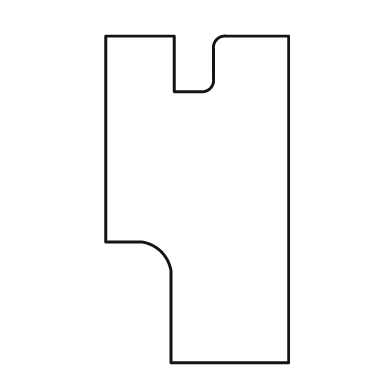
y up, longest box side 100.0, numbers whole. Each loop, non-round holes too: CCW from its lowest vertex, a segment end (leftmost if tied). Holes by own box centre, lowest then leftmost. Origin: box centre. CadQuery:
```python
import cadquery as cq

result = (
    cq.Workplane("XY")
    .moveTo(-8.0, -50.0)
    .lineTo(28.0, -50.0)
    .lineTo(28.0, 50.0)
    .lineTo(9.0, 50.0)
    .threePointArc((6.0, 49.0), (5.0, 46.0))
    .lineTo(5.0, 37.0)
    .threePointArc((4.0, 34.0), (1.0, 33.0))
    .lineTo(-7.0, 33.0)
    .lineTo(-7.0, 50.0)
    .lineTo(-28.0, 50.0)
    .lineTo(-28.0, -13.0)
    .lineTo(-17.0, -13.0)
    .threePointArc((-11.0, -16.0), (-8.0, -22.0))
    .close()
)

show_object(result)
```